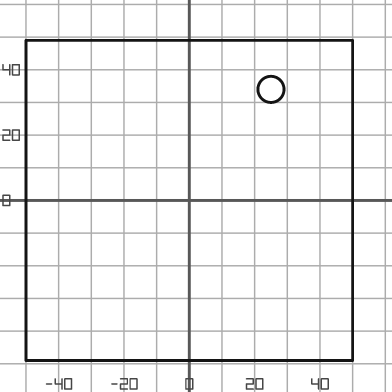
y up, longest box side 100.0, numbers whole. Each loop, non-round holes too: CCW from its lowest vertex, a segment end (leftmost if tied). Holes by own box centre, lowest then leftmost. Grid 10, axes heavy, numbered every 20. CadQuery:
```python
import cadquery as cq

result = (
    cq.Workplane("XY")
    .moveTo(-50.0, -49.0)
    .lineTo(50.0, -49.0)
    .lineTo(50.0, 49.0)
    .lineTo(-50.0, 49.0)
    .close()
    .moveTo(25.0, 34.0)
    .circle(4.0)
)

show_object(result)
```